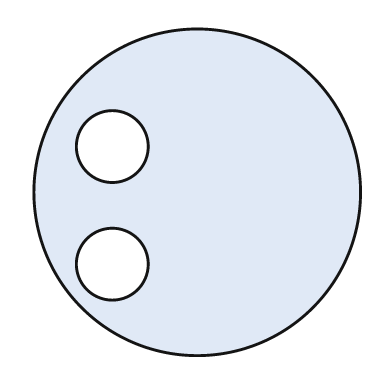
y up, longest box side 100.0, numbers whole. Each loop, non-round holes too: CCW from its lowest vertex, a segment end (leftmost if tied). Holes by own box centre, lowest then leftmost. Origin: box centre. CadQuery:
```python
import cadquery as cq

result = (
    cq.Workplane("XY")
    .moveTo(0.0, 0.0)
    .circle(50.0)
    .moveTo(-26.0, -22.0)
    .circle(11.0)
    .moveTo(-26.0, 14.0)
    .circle(11.0)
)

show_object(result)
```